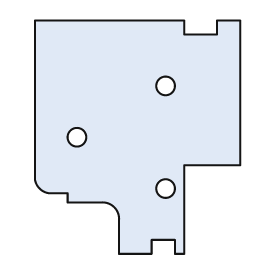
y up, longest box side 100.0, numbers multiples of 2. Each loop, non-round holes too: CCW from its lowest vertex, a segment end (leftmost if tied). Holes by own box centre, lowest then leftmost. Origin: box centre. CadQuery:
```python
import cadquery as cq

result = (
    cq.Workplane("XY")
    .moveTo(-8.0, -50.0)
    .lineTo(6.0, -50.0)
    .lineTo(6.0, -44.0)
    .lineTo(16.0, -44.0)
    .lineTo(16.0, -50.0)
    .lineTo(20.0, -50.0)
    .lineTo(20.0, -12.0)
    .lineTo(44.0, -12.0)
    .lineTo(44.0, 50.0)
    .lineTo(34.0, 50.0)
    .lineTo(34.0, 44.0)
    .lineTo(20.0, 44.0)
    .lineTo(20.0, 50.0)
    .lineTo(-44.0, 50.0)
    .lineTo(-44.0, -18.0)
    .threePointArc((-42.0, -22.0), (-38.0, -24.0))
    .lineTo(-30.0, -24.0)
    .lineTo(-30.0, -28.0)
    .lineTo(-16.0, -28.0)
    .threePointArc((-10.0, -30.0), (-8.0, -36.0))
    .close()
    .moveTo(12.0, -22.0)
    .circle(4.0)
    .moveTo(-26.0, 0.0)
    .circle(4.0)
    .moveTo(12.0, 22.0)
    .circle(4.0)
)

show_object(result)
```